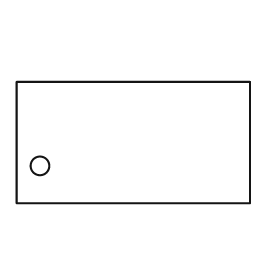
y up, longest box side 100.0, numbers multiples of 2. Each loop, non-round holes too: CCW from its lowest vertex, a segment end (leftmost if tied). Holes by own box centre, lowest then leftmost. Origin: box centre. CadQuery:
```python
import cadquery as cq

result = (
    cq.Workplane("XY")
    .moveTo(-50.0, -26.0)
    .lineTo(50.0, -26.0)
    .lineTo(50.0, 26.0)
    .lineTo(-50.0, 26.0)
    .close()
    .moveTo(-40.0, -10.0)
    .circle(4.0)
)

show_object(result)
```